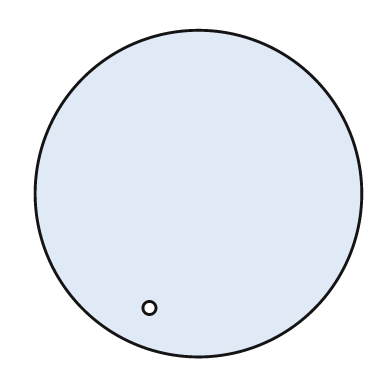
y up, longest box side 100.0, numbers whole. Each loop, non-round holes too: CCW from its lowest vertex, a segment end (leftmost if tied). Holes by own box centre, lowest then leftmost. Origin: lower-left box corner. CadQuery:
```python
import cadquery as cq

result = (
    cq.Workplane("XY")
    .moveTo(50.0, 50.0)
    .circle(50.0)
    .moveTo(35.0, 15.0)
    .circle(2.0)
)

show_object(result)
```